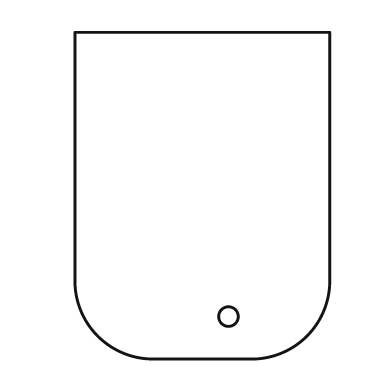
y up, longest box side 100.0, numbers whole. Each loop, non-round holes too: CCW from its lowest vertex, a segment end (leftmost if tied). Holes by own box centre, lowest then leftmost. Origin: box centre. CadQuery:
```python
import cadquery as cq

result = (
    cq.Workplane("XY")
    .moveTo(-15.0, -50.0)
    .lineTo(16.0, -50.0)
    .threePointArc((32.0, -43.0), (39.0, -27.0))
    .lineTo(39.0, 50.0)
    .lineTo(-39.0, 50.0)
    .lineTo(-39.0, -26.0)
    .threePointArc((-32.0, -43.0), (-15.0, -50.0))
    .close()
    .moveTo(8.0, -37.0)
    .circle(3.0)
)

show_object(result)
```